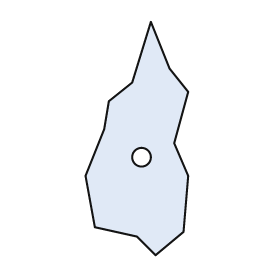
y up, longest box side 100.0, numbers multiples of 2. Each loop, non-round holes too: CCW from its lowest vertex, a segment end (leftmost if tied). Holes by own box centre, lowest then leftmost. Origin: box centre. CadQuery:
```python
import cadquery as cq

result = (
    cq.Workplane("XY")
    .moveTo(8.0, -50.0)
    .lineTo(20.0, -40.0)
    .lineTo(22.0, -16.0)
    .lineTo(16.0, -2.0)
    .lineTo(22.0, 20.0)
    .lineTo(14.0, 30.0)
    .lineTo(6.0, 50.0)
    .lineTo(-2.0, 24.0)
    .lineTo(-12.0, 16.0)
    .lineTo(-14.0, 4.0)
    .lineTo(-22.0, -16.0)
    .lineTo(-18.0, -38.0)
    .lineTo(0.0, -42.0)
    .close()
    .moveTo(2.0, -8.0)
    .circle(4.0)
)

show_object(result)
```